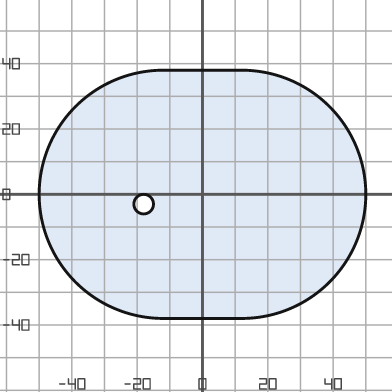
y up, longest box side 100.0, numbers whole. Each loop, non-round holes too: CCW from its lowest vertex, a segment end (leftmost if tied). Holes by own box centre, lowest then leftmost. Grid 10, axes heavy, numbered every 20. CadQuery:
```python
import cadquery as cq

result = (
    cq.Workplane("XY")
    .moveTo(-12.0, -38.0)
    .lineTo(12.0, -38.0)
    .threePointArc((50.0, 0.0), (12.0, 38.0))
    .lineTo(-12.0, 38.0)
    .threePointArc((-50.0, 0.0), (-12.0, -38.0))
    .close()
    .moveTo(-18.0, -3.0)
    .circle(3.0)
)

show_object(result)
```